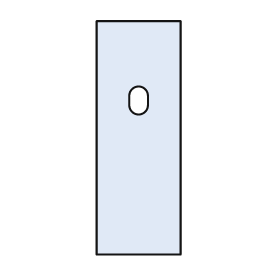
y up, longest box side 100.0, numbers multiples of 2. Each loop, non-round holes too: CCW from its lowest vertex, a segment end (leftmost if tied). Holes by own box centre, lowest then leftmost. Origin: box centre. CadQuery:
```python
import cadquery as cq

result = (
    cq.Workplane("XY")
    .moveTo(-18.0, -50.0)
    .lineTo(18.0, -50.0)
    .lineTo(18.0, 50.0)
    .lineTo(-18.0, 50.0)
    .close()
    .moveTo(-4.0, 14.0)
    .threePointArc((0.0, 10.0), (4.0, 14.0))
    .lineTo(4.0, 18.0)
    .threePointArc((0.0, 22.0), (-4.0, 18.0))
    .close()
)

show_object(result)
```